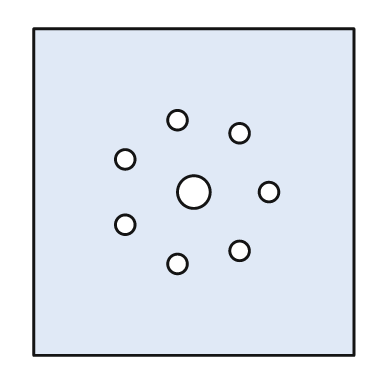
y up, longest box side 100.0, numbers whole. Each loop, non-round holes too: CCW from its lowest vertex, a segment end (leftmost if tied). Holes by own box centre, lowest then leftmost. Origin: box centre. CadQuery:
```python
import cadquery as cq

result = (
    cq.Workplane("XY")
    .moveTo(-49.0, -50.0)
    .lineTo(49.0, -50.0)
    .lineTo(49.0, 50.0)
    .lineTo(-49.0, 50.0)
    .close()
    .moveTo(-5.0, -22.0)
    .circle(3.0)
    .moveTo(14.0, -18.0)
    .circle(3.0)
    .moveTo(-21.0, -10.0)
    .circle(3.0)
    .moveTo(0.0, 0.0)
    .circle(5.0)
    .moveTo(23.0, 0.0)
    .circle(3.0)
    .moveTo(-21.0, 10.0)
    .circle(3.0)
    .moveTo(14.0, 18.0)
    .circle(3.0)
    .moveTo(-5.0, 22.0)
    .circle(3.0)
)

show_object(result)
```